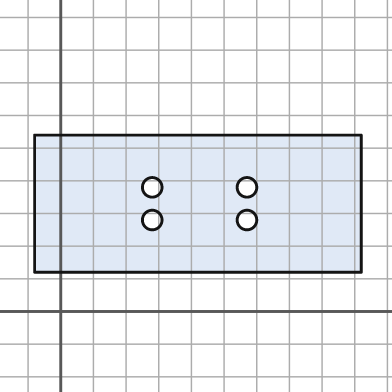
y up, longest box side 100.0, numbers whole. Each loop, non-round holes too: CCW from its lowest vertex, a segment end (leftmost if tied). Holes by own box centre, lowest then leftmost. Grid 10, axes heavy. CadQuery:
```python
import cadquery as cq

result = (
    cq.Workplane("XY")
    .moveTo(-8.0, 12.0)
    .lineTo(92.0, 12.0)
    .lineTo(92.0, 54.0)
    .lineTo(-8.0, 54.0)
    .close()
    .moveTo(28.0, 28.0)
    .circle(3.0)
    .moveTo(57.0, 28.0)
    .circle(3.0)
    .moveTo(28.0, 38.0)
    .circle(3.0)
    .moveTo(57.0, 38.0)
    .circle(3.0)
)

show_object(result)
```